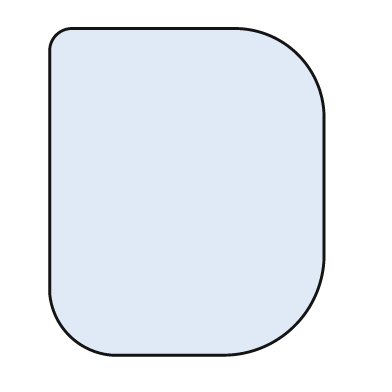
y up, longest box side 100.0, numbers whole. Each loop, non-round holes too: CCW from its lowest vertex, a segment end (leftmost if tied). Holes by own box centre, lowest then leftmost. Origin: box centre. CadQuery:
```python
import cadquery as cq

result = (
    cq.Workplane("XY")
    .moveTo(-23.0, -50.0)
    .lineTo(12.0, -50.0)
    .threePointArc((33.0, -41.0), (42.0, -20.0))
    .lineTo(42.0, 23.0)
    .threePointArc((34.0, 42.0), (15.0, 50.0))
    .lineTo(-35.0, 50.0)
    .threePointArc((-40.0, 48.0), (-42.0, 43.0))
    .lineTo(-42.0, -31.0)
    .threePointArc((-36.0, -44.0), (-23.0, -50.0))
    .close()
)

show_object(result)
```